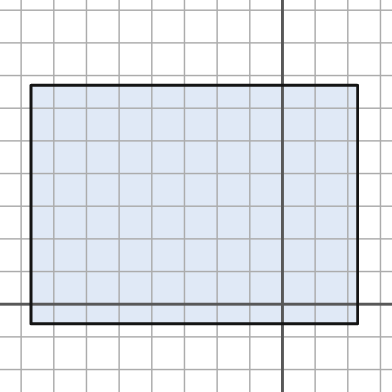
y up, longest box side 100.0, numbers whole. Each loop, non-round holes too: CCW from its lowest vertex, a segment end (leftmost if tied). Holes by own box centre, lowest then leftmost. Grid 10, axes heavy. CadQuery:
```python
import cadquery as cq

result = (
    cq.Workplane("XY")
    .moveTo(-77.0, -6.0)
    .lineTo(23.0, -6.0)
    .lineTo(23.0, 67.0)
    .lineTo(-77.0, 67.0)
    .close()
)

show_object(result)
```